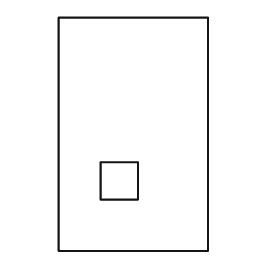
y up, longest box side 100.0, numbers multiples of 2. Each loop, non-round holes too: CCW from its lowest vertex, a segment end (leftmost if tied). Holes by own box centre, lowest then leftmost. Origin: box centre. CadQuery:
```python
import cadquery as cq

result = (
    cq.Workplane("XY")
    .moveTo(-32.0, -50.0)
    .lineTo(32.0, -50.0)
    .lineTo(32.0, 50.0)
    .lineTo(-32.0, 50.0)
    .close()
    .moveTo(-14.0, -28.0)
    .lineTo(2.0, -28.0)
    .lineTo(2.0, -12.0)
    .lineTo(-14.0, -12.0)
    .close()
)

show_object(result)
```